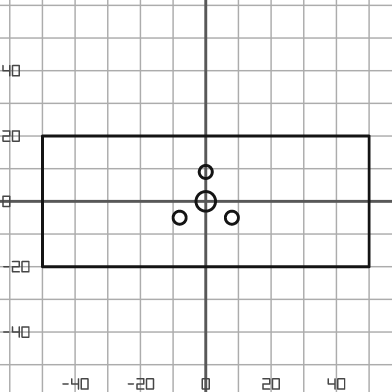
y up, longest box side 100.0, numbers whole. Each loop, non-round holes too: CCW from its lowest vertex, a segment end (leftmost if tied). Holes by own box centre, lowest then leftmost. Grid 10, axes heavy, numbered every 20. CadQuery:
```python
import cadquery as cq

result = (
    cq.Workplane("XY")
    .moveTo(-50.0, -20.0)
    .lineTo(50.0, -20.0)
    .lineTo(50.0, 20.0)
    .lineTo(-50.0, 20.0)
    .close()
    .moveTo(-8.0, -5.0)
    .circle(2.0)
    .moveTo(8.0, -5.0)
    .circle(2.0)
    .moveTo(0.0, 0.0)
    .circle(3.0)
    .moveTo(0.0, 9.0)
    .circle(2.0)
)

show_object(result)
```